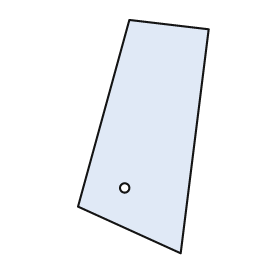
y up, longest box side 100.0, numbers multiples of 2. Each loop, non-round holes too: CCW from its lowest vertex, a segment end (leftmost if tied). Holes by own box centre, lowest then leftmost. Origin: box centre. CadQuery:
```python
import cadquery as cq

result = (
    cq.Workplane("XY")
    .moveTo(16.0, -50.0)
    .lineTo(28.0, 46.0)
    .lineTo(-6.0, 50.0)
    .lineTo(-28.0, -30.0)
    .close()
    .moveTo(-8.0, -22.0)
    .circle(2.0)
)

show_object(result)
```